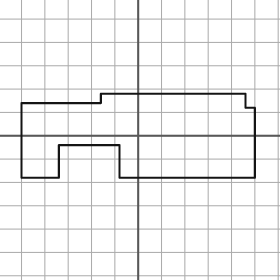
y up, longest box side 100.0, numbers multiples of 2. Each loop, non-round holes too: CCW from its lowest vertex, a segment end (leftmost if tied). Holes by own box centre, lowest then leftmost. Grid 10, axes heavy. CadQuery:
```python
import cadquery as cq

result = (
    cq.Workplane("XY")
    .moveTo(-50.0, -18.0)
    .lineTo(-34.0, -18.0)
    .lineTo(-34.0, -4.0)
    .lineTo(-8.0, -4.0)
    .lineTo(-8.0, -18.0)
    .lineTo(50.0, -18.0)
    .lineTo(50.0, 12.0)
    .lineTo(46.0, 12.0)
    .lineTo(46.0, 18.0)
    .lineTo(-16.0, 18.0)
    .lineTo(-16.0, 14.0)
    .lineTo(-50.0, 14.0)
    .close()
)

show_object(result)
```